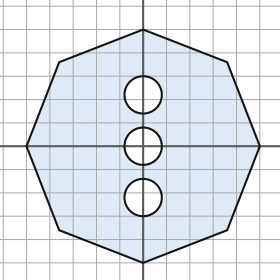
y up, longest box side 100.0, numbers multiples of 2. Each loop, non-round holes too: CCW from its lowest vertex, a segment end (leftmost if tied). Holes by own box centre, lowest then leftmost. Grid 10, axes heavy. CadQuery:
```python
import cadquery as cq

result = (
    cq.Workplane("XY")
    .moveTo(0.0, -50.0)
    .lineTo(36.0, -36.0)
    .lineTo(50.0, 0.0)
    .lineTo(36.0, 36.0)
    .lineTo(0.0, 50.0)
    .lineTo(-36.0, 36.0)
    .lineTo(-50.0, 0.0)
    .lineTo(-36.0, -36.0)
    .close()
    .moveTo(0.0, -22.0)
    .circle(8.0)
    .moveTo(0.0, 0.0)
    .circle(8.0)
    .moveTo(0.0, 22.0)
    .circle(8.0)
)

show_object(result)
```